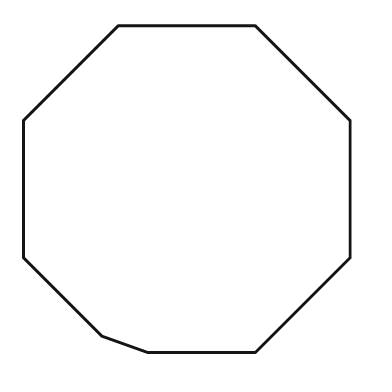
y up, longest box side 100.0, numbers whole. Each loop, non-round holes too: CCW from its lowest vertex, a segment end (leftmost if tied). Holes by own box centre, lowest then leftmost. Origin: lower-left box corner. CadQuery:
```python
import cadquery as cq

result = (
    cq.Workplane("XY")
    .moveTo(38.0, 0.0)
    .lineTo(71.0, 0.0)
    .lineTo(100.0, 29.0)
    .lineTo(100.0, 71.0)
    .lineTo(71.0, 100.0)
    .lineTo(29.0, 100.0)
    .lineTo(0.0, 71.0)
    .lineTo(0.0, 29.0)
    .lineTo(24.0, 5.0)
    .close()
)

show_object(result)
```